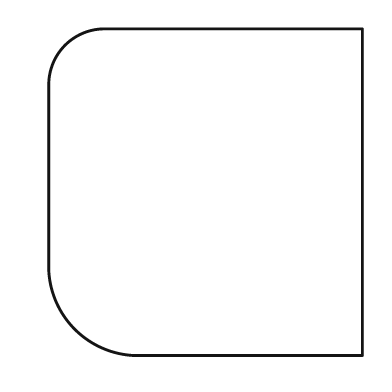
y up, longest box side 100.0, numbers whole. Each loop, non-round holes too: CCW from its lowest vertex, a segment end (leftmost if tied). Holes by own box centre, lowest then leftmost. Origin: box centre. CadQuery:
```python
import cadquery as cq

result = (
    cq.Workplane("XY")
    .moveTo(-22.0, -50.0)
    .lineTo(48.0, -50.0)
    .lineTo(48.0, 50.0)
    .lineTo(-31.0, 50.0)
    .threePointArc((-43.0, 45.0), (-48.0, 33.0))
    .lineTo(-48.0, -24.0)
    .threePointArc((-40.0, -42.0), (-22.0, -50.0))
    .close()
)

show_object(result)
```